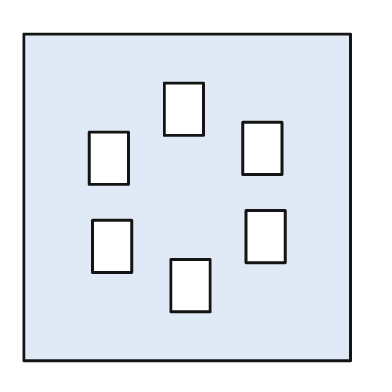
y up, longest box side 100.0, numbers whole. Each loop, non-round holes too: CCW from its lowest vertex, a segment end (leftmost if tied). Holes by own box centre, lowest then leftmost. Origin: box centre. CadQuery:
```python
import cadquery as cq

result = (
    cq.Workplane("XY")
    .moveTo(-50.0, -50.0)
    .lineTo(50.0, -50.0)
    .lineTo(50.0, 50.0)
    .lineTo(-50.0, 50.0)
    .close()
    .moveTo(-5.0, -35.0)
    .lineTo(7.0, -35.0)
    .lineTo(7.0, -19.0)
    .lineTo(-5.0, -19.0)
    .close()
    .moveTo(-29.0, -23.0)
    .lineTo(-17.0, -23.0)
    .lineTo(-17.0, -7.0)
    .lineTo(-29.0, -7.0)
    .close()
    .moveTo(18.0, -20.0)
    .lineTo(30.0, -20.0)
    .lineTo(30.0, -4.0)
    .lineTo(18.0, -4.0)
    .close()
    .moveTo(-30.0, 4.0)
    .lineTo(-18.0, 4.0)
    .lineTo(-18.0, 20.0)
    .lineTo(-30.0, 20.0)
    .close()
    .moveTo(17.0, 7.0)
    .lineTo(29.0, 7.0)
    .lineTo(29.0, 23.0)
    .lineTo(17.0, 23.0)
    .close()
    .moveTo(-7.0, 19.0)
    .lineTo(5.0, 19.0)
    .lineTo(5.0, 35.0)
    .lineTo(-7.0, 35.0)
    .close()
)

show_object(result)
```